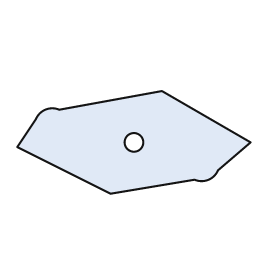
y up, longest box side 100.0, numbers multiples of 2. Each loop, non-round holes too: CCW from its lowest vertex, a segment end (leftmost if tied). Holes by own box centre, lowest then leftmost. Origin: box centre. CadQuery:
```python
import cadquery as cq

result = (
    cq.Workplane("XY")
    .moveTo(-10.0, -22.0)
    .lineTo(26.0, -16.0)
    .threePointArc((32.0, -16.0), (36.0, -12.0))
    .lineTo(50.0, 0.0)
    .lineTo(12.0, 22.0)
    .lineTo(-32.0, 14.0)
    .threePointArc((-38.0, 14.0), (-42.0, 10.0))
    .lineTo(-50.0, -2.0)
    .close()
    .moveTo(0.0, 0.0)
    .circle(4.0)
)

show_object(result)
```